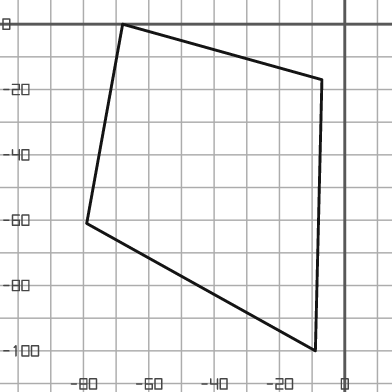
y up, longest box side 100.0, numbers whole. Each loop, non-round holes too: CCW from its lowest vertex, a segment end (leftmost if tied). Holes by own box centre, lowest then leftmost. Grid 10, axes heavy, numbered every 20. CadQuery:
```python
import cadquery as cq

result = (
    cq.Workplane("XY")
    .moveTo(-9.0, -100.0)
    .lineTo(-7.0, -17.0)
    .lineTo(-68.0, 0.0)
    .lineTo(-79.0, -61.0)
    .close()
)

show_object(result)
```